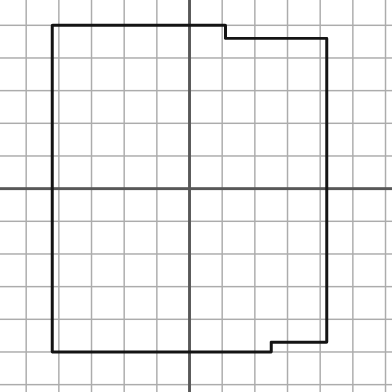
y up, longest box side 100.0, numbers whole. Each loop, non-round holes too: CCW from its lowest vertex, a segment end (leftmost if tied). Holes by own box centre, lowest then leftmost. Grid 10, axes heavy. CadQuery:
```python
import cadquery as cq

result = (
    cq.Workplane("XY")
    .moveTo(-42.0, -50.0)
    .lineTo(25.0, -50.0)
    .lineTo(25.0, -47.0)
    .lineTo(42.0, -47.0)
    .lineTo(42.0, 46.0)
    .lineTo(11.0, 46.0)
    .lineTo(11.0, 50.0)
    .lineTo(-42.0, 50.0)
    .close()
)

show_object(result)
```